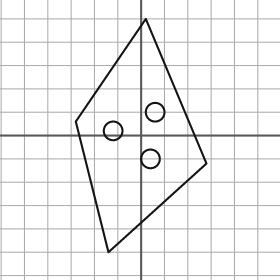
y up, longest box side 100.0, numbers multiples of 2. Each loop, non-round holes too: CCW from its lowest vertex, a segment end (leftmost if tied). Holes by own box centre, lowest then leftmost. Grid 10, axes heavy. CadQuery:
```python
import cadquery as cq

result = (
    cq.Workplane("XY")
    .moveTo(-14.0, -50.0)
    .lineTo(28.0, -12.0)
    .lineTo(2.0, 50.0)
    .lineTo(-28.0, 6.0)
    .close()
    .moveTo(4.0, -10.0)
    .circle(4.0)
    .moveTo(-12.0, 2.0)
    .circle(4.0)
    .moveTo(6.0, 10.0)
    .circle(4.0)
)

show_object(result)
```